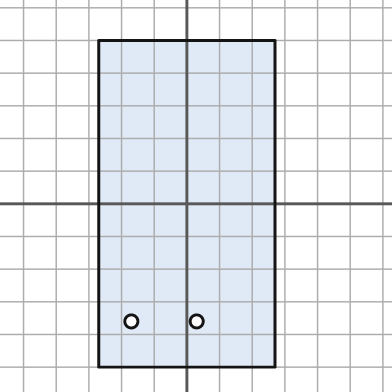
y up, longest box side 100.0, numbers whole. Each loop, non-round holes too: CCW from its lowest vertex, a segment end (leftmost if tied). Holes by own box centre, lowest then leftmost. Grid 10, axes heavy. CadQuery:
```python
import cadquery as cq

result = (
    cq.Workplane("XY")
    .moveTo(-27.0, -50.0)
    .lineTo(27.0, -50.0)
    .lineTo(27.0, 50.0)
    .lineTo(-27.0, 50.0)
    .close()
    .moveTo(-17.0, -36.0)
    .circle(2.0)
    .moveTo(3.0, -36.0)
    .circle(2.0)
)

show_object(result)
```